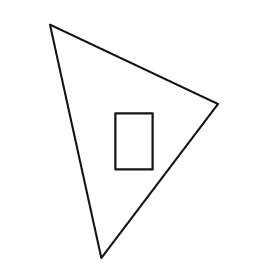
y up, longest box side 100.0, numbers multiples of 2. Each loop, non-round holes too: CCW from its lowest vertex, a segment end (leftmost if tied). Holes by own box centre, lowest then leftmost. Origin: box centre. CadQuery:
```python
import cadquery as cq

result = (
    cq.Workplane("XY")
    .moveTo(-14.0, -50.0)
    .lineTo(36.0, 16.0)
    .lineTo(-36.0, 50.0)
    .close()
    .moveTo(-8.0, -12.0)
    .lineTo(8.0, -12.0)
    .lineTo(8.0, 12.0)
    .lineTo(-8.0, 12.0)
    .close()
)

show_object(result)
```